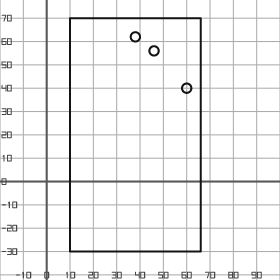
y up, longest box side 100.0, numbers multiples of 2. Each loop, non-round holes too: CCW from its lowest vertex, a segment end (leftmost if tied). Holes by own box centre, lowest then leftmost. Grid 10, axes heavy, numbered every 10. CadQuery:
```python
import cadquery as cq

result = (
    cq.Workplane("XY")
    .moveTo(10.0, -30.0)
    .lineTo(66.0, -30.0)
    .lineTo(66.0, 70.0)
    .lineTo(10.0, 70.0)
    .close()
    .moveTo(60.0, 40.0)
    .circle(2.0)
    .moveTo(46.0, 56.0)
    .circle(2.0)
    .moveTo(38.0, 62.0)
    .circle(2.0)
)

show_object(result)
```